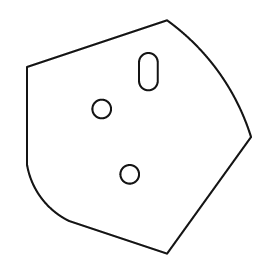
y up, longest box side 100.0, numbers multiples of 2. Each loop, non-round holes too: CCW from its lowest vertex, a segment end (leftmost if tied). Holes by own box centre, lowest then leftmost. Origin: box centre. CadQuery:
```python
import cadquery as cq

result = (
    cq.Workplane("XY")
    .moveTo(12.0, -50.0)
    .lineTo(48.0, 0.0)
    .threePointArc((34.0, 28.0), (12.0, 50.0))
    .lineTo(-48.0, 30.0)
    .lineTo(-48.0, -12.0)
    .threePointArc((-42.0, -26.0), (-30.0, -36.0))
    .close()
    .moveTo(-4.0, -16.0)
    .circle(4.0)
    .moveTo(-16.0, 12.0)
    .circle(4.0)
    .moveTo(0.0, 24.0)
    .threePointArc((4.0, 20.0), (8.0, 24.0))
    .lineTo(8.0, 32.0)
    .threePointArc((4.0, 36.0), (0.0, 32.0))
    .close()
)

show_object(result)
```